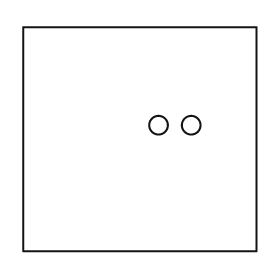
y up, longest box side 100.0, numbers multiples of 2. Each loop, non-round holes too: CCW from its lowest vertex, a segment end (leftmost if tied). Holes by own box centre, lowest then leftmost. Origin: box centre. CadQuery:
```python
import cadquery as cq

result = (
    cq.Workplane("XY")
    .moveTo(-50.0, -48.0)
    .lineTo(50.0, -48.0)
    .lineTo(50.0, 48.0)
    .lineTo(-50.0, 48.0)
    .close()
    .moveTo(8.0, 6.0)
    .circle(4.0)
    .moveTo(22.0, 6.0)
    .circle(4.0)
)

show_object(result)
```